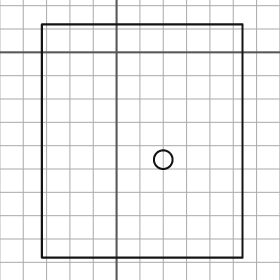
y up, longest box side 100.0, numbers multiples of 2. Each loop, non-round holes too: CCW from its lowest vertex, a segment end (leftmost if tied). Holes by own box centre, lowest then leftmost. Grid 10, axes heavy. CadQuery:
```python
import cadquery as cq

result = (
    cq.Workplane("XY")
    .moveTo(-32.0, -88.0)
    .lineTo(54.0, -88.0)
    .lineTo(54.0, 12.0)
    .lineTo(-32.0, 12.0)
    .close()
    .moveTo(20.0, -46.0)
    .circle(4.0)
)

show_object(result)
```